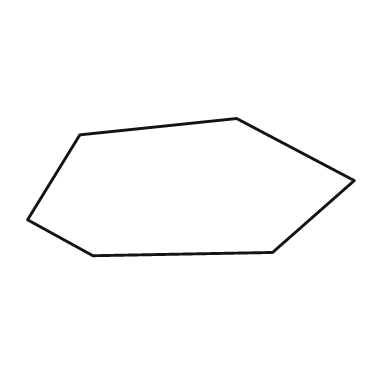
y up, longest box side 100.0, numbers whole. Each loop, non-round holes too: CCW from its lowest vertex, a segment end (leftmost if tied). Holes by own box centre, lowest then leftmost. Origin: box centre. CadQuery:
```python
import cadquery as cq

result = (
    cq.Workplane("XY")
    .moveTo(-30.0, -21.0)
    .lineTo(25.0, -20.0)
    .lineTo(50.0, 2.0)
    .lineTo(14.0, 21.0)
    .lineTo(-34.0, 16.0)
    .lineTo(-50.0, -10.0)
    .close()
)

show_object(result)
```